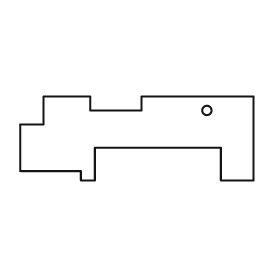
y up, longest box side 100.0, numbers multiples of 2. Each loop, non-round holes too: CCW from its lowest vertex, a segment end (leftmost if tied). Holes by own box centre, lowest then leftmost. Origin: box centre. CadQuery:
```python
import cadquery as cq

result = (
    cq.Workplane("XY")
    .moveTo(-24.0, -18.0)
    .lineTo(-18.0, -18.0)
    .lineTo(-18.0, -4.0)
    .lineTo(36.0, -4.0)
    .lineTo(36.0, -18.0)
    .lineTo(50.0, -18.0)
    .lineTo(50.0, 18.0)
    .lineTo(2.0, 18.0)
    .lineTo(2.0, 12.0)
    .lineTo(-20.0, 12.0)
    .lineTo(-20.0, 18.0)
    .lineTo(-40.0, 18.0)
    .lineTo(-40.0, 6.0)
    .lineTo(-50.0, 6.0)
    .lineTo(-50.0, -14.0)
    .lineTo(-24.0, -14.0)
    .close()
    .moveTo(30.0, 12.0)
    .circle(2.0)
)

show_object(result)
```